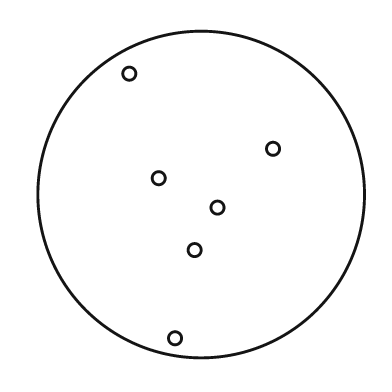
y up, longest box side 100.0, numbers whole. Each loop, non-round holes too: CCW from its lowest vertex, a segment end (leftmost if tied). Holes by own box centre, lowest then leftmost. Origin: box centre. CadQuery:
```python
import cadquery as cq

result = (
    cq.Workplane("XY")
    .moveTo(0.0, 0.0)
    .circle(50.0)
    .moveTo(-8.0, -44.0)
    .circle(2.0)
    .moveTo(-2.0, -17.0)
    .circle(2.0)
    .moveTo(5.0, -4.0)
    .circle(2.0)
    .moveTo(-13.0, 5.0)
    .circle(2.0)
    .moveTo(22.0, 14.0)
    .circle(2.0)
    .moveTo(-22.0, 37.0)
    .circle(2.0)
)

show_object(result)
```